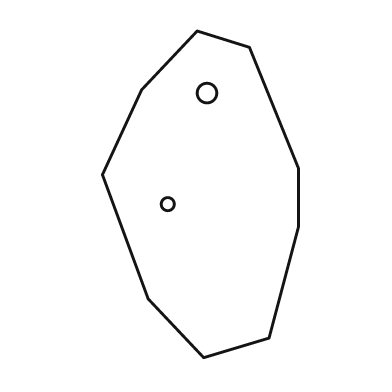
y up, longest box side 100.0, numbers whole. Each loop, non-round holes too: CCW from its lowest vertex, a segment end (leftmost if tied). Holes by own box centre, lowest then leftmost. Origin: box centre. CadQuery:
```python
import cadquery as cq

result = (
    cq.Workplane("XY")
    .moveTo(1.0, -50.0)
    .lineTo(21.0, -44.0)
    .lineTo(30.0, -10.0)
    .lineTo(30.0, 8.0)
    .lineTo(15.0, 45.0)
    .lineTo(-1.0, 50.0)
    .lineTo(-18.0, 32.0)
    .lineTo(-30.0, 6.0)
    .lineTo(-16.0, -32.0)
    .close()
    .moveTo(-10.0, -3.0)
    .circle(2.0)
    .moveTo(2.0, 31.0)
    .circle(3.0)
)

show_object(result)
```